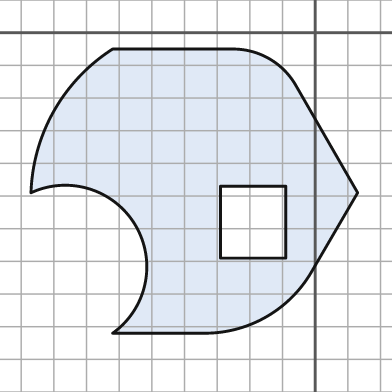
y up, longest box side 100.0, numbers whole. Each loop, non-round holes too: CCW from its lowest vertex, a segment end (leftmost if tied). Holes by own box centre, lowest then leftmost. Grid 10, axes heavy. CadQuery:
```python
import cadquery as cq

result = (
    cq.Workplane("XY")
    .moveTo(-62.0, -92.0)
    .lineTo(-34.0, -92.0)
    .threePointArc((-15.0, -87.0), (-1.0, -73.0))
    .lineTo(13.0, -49.0)
    .lineTo(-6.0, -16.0)
    .threePointArc((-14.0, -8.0), (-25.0, -5.0))
    .lineTo(-62.0, -5.0)
    .threePointArc((-80.0, -24.0), (-87.0, -49.0))
    .threePointArc((-55.0, -59.0), (-62.0, -92.0))
    .close()
    .moveTo(-29.0, -69.0)
    .lineTo(-9.0, -69.0)
    .lineTo(-9.0, -47.0)
    .lineTo(-29.0, -47.0)
    .close()
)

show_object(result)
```